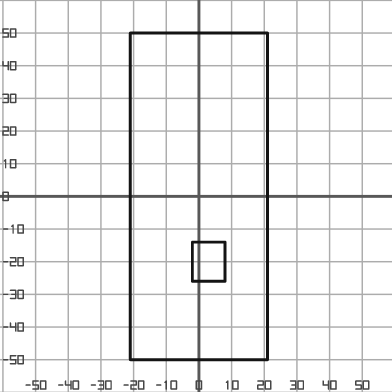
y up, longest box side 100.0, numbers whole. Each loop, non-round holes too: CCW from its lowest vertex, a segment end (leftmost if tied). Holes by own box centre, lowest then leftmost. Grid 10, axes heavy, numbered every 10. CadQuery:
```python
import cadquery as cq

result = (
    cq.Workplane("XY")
    .moveTo(-21.0, -50.0)
    .lineTo(21.0, -50.0)
    .lineTo(21.0, 50.0)
    .lineTo(-21.0, 50.0)
    .close()
    .moveTo(-2.0, -26.0)
    .lineTo(8.0, -26.0)
    .lineTo(8.0, -14.0)
    .lineTo(-2.0, -14.0)
    .close()
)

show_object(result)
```